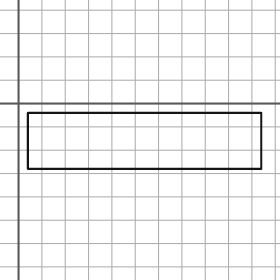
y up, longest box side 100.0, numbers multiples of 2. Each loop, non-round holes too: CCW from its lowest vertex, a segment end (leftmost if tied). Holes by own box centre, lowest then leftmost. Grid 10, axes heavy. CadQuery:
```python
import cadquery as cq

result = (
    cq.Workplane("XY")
    .moveTo(4.0, -28.0)
    .lineTo(104.0, -28.0)
    .lineTo(104.0, -4.0)
    .lineTo(4.0, -4.0)
    .close()
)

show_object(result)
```